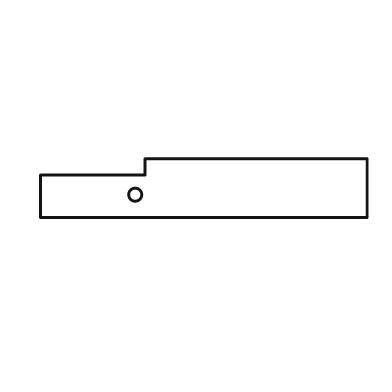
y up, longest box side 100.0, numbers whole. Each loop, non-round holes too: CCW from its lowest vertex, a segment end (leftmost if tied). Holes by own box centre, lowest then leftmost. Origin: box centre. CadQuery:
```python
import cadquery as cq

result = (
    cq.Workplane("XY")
    .moveTo(-50.0, -9.0)
    .lineTo(50.0, -9.0)
    .lineTo(50.0, 9.0)
    .lineTo(-18.0, 9.0)
    .lineTo(-18.0, 4.0)
    .lineTo(-50.0, 4.0)
    .close()
    .moveTo(-21.0, -2.0)
    .circle(2.0)
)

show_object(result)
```